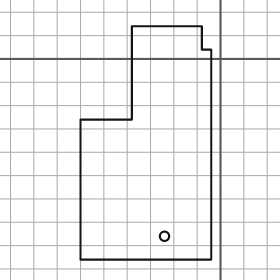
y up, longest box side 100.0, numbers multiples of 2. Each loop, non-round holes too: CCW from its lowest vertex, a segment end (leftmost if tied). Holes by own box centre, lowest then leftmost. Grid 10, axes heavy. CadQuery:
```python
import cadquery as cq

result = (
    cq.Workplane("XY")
    .moveTo(-60.0, -86.0)
    .lineTo(-4.0, -86.0)
    .lineTo(-4.0, 4.0)
    .lineTo(-8.0, 4.0)
    .lineTo(-8.0, 14.0)
    .lineTo(-38.0, 14.0)
    .lineTo(-38.0, -26.0)
    .lineTo(-60.0, -26.0)
    .close()
    .moveTo(-24.0, -76.0)
    .circle(2.0)
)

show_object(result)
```